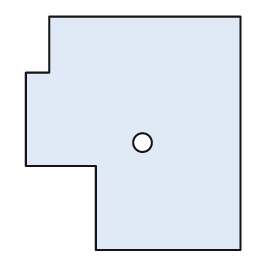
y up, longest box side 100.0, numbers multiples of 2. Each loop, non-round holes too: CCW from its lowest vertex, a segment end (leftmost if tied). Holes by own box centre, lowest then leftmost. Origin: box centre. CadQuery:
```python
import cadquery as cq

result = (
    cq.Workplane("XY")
    .moveTo(-16.0, -50.0)
    .lineTo(46.0, -50.0)
    .lineTo(46.0, 50.0)
    .lineTo(-36.0, 50.0)
    .lineTo(-36.0, 26.0)
    .lineTo(-46.0, 26.0)
    .lineTo(-46.0, -14.0)
    .lineTo(-16.0, -14.0)
    .close()
    .moveTo(4.0, -4.0)
    .circle(4.0)
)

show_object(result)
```